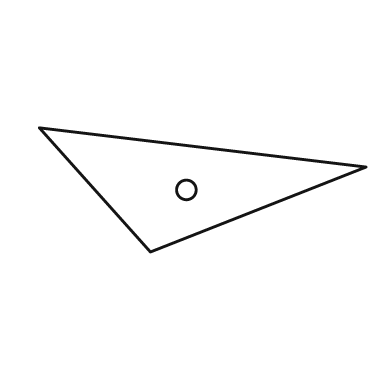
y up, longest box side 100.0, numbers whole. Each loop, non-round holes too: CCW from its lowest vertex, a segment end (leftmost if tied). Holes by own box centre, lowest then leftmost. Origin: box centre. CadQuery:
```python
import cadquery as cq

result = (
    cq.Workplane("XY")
    .moveTo(-16.0, -19.0)
    .lineTo(50.0, 7.0)
    .lineTo(-50.0, 19.0)
    .close()
    .moveTo(-5.0, 0.0)
    .circle(3.0)
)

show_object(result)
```